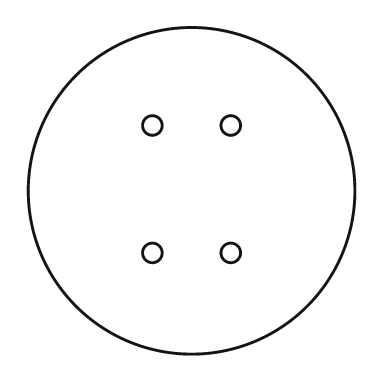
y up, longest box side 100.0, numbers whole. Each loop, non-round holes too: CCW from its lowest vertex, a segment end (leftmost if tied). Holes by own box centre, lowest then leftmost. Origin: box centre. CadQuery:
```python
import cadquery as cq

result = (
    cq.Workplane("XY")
    .moveTo(0.0, 0.0)
    .circle(50.0)
    .moveTo(-12.0, -19.0)
    .circle(3.0)
    .moveTo(12.0, -19.0)
    .circle(3.0)
    .moveTo(-12.0, 20.0)
    .circle(3.0)
    .moveTo(12.0, 20.0)
    .circle(3.0)
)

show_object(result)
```